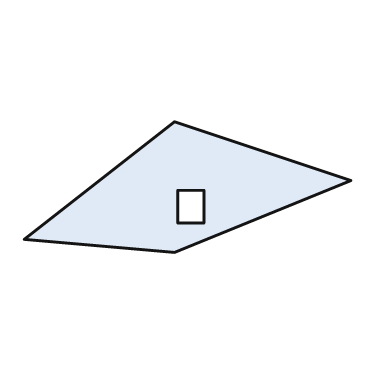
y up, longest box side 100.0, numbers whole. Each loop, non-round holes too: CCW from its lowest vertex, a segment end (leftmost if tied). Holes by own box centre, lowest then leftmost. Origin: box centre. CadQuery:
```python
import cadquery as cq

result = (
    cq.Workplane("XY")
    .moveTo(-4.0, -20.0)
    .lineTo(50.0, 2.0)
    .lineTo(-4.0, 20.0)
    .lineTo(-50.0, -16.0)
    .close()
    .moveTo(-3.0, -11.0)
    .lineTo(5.0, -11.0)
    .lineTo(5.0, -1.0)
    .lineTo(-3.0, -1.0)
    .close()
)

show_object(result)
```